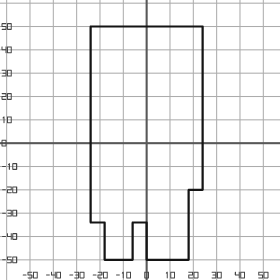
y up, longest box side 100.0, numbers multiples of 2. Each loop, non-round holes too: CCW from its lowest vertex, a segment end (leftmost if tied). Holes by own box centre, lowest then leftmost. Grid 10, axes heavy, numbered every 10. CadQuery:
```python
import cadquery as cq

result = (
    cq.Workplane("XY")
    .moveTo(-18.0, -50.0)
    .lineTo(-6.0, -50.0)
    .lineTo(-6.0, -34.0)
    .lineTo(0.0, -34.0)
    .lineTo(0.0, -50.0)
    .lineTo(18.0, -50.0)
    .lineTo(18.0, -20.0)
    .lineTo(24.0, -20.0)
    .lineTo(24.0, 50.0)
    .lineTo(-24.0, 50.0)
    .lineTo(-24.0, -34.0)
    .lineTo(-18.0, -34.0)
    .close()
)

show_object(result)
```